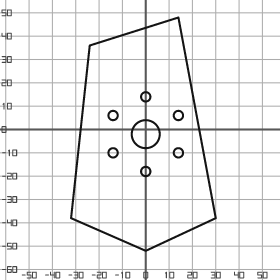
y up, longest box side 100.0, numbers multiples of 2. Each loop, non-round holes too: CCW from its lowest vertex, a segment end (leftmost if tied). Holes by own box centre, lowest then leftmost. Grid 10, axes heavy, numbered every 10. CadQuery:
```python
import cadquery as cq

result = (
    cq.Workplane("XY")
    .moveTo(0.0, -52.0)
    .lineTo(30.0, -38.0)
    .lineTo(14.0, 48.0)
    .lineTo(-24.0, 36.0)
    .lineTo(-32.0, -38.0)
    .close()
    .moveTo(0.0, -18.0)
    .circle(2.0)
    .moveTo(-14.0, -10.0)
    .circle(2.0)
    .moveTo(14.0, -10.0)
    .circle(2.0)
    .moveTo(0.0, -2.0)
    .circle(6.0)
    .moveTo(-14.0, 6.0)
    .circle(2.0)
    .moveTo(14.0, 6.0)
    .circle(2.0)
    .moveTo(0.0, 14.0)
    .circle(2.0)
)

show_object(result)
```